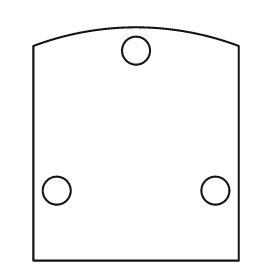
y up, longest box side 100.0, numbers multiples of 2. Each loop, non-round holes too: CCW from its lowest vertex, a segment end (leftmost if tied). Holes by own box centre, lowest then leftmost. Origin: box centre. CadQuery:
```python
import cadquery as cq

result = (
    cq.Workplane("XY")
    .moveTo(-44.0, -50.0)
    .lineTo(44.0, -50.0)
    .lineTo(44.0, 42.0)
    .threePointArc((0.0, 50.0), (-44.0, 42.0))
    .close()
    .moveTo(-34.0, -20.0)
    .circle(6.0)
    .moveTo(34.0, -20.0)
    .circle(6.0)
    .moveTo(0.0, 40.0)
    .circle(6.0)
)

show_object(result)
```